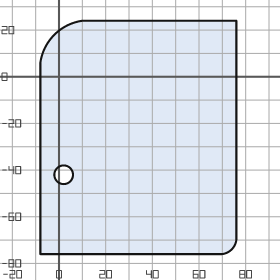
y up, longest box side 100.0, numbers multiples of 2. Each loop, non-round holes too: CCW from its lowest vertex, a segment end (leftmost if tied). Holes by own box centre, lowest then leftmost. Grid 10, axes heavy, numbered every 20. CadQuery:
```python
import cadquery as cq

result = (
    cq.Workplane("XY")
    .moveTo(-8.0, -76.0)
    .lineTo(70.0, -76.0)
    .threePointArc((74.0, -74.0), (76.0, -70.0))
    .lineTo(76.0, 24.0)
    .lineTo(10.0, 24.0)
    .threePointArc((-2.0, 18.0), (-8.0, 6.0))
    .close()
    .moveTo(2.0, -42.0)
    .circle(4.0)
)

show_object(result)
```